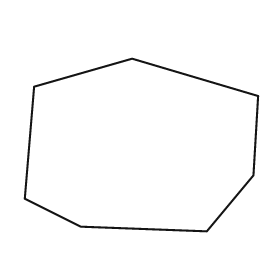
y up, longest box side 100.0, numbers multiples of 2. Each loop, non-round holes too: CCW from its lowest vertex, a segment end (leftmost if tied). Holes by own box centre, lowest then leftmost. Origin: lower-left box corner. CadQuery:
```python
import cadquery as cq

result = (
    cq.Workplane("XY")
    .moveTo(78.0, 0.0)
    .lineTo(98.0, 24.0)
    .lineTo(100.0, 58.0)
    .lineTo(46.0, 74.0)
    .lineTo(4.0, 62.0)
    .lineTo(0.0, 14.0)
    .lineTo(24.0, 2.0)
    .close()
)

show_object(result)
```